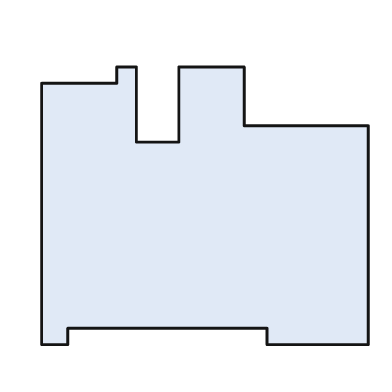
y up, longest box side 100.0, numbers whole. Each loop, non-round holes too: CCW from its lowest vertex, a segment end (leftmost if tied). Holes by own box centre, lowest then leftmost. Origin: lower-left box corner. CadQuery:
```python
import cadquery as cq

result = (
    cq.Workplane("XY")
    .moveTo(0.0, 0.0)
    .lineTo(8.0, 0.0)
    .lineTo(8.0, 5.0)
    .lineTo(69.0, 5.0)
    .lineTo(69.0, 0.0)
    .lineTo(100.0, 0.0)
    .lineTo(100.0, 67.0)
    .lineTo(62.0, 67.0)
    .lineTo(62.0, 85.0)
    .lineTo(42.0, 85.0)
    .lineTo(42.0, 62.0)
    .lineTo(29.0, 62.0)
    .lineTo(29.0, 85.0)
    .lineTo(23.0, 85.0)
    .lineTo(23.0, 80.0)
    .lineTo(0.0, 80.0)
    .close()
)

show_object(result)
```